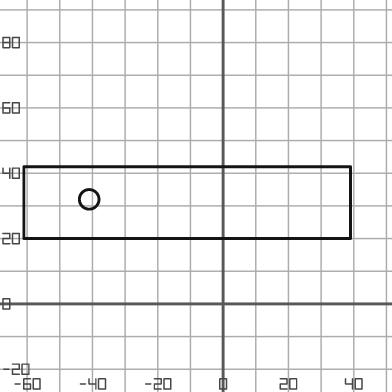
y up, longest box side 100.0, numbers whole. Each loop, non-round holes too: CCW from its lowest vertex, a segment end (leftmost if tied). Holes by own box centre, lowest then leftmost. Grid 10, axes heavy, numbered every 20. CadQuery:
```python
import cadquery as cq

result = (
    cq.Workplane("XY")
    .moveTo(-61.0, 20.0)
    .lineTo(39.0, 20.0)
    .lineTo(39.0, 42.0)
    .lineTo(-61.0, 42.0)
    .close()
    .moveTo(-41.0, 32.0)
    .circle(3.0)
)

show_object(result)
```